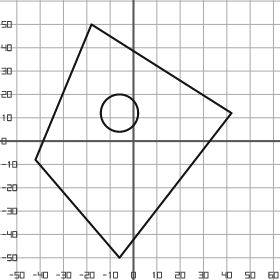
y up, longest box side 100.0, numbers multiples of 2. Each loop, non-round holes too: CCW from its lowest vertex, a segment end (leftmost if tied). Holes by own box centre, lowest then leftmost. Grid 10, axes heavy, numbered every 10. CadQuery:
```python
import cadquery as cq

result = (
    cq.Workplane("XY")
    .moveTo(-6.0, -50.0)
    .lineTo(42.0, 12.0)
    .lineTo(-18.0, 50.0)
    .lineTo(-42.0, -8.0)
    .close()
    .moveTo(-6.0, 12.0)
    .circle(8.0)
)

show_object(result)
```